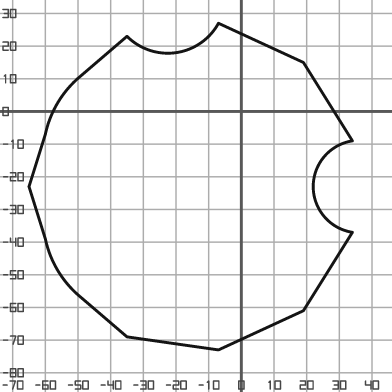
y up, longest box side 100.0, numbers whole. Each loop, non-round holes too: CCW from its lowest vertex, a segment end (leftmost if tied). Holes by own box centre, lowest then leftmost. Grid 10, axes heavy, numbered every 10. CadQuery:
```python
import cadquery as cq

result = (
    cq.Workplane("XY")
    .moveTo(-7.0, -73.0)
    .lineTo(19.0, -61.0)
    .lineTo(34.0, -37.0)
    .threePointArc((22.0, -23.0), (34.0, -9.0))
    .lineTo(19.0, 15.0)
    .lineTo(-7.0, 27.0)
    .threePointArc((-20.0, 18.0), (-35.0, 23.0))
    .lineTo(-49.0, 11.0)
    .threePointArc((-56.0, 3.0), (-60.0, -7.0))
    .lineTo(-65.0, -23.0)
    .lineTo(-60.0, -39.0)
    .threePointArc((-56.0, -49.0), (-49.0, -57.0))
    .lineTo(-35.0, -69.0)
    .close()
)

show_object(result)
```